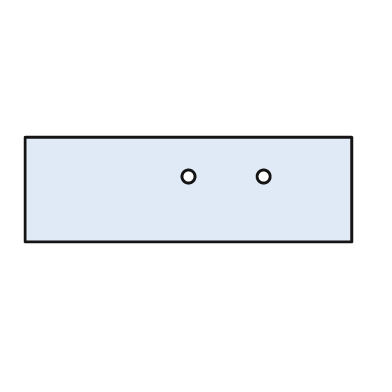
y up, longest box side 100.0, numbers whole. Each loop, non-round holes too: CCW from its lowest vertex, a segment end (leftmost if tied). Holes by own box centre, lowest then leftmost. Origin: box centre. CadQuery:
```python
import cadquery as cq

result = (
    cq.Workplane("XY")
    .moveTo(-50.0, -16.0)
    .lineTo(50.0, -16.0)
    .lineTo(50.0, 16.0)
    .lineTo(-50.0, 16.0)
    .close()
    .moveTo(0.0, 4.0)
    .circle(2.0)
    .moveTo(23.0, 4.0)
    .circle(2.0)
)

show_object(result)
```